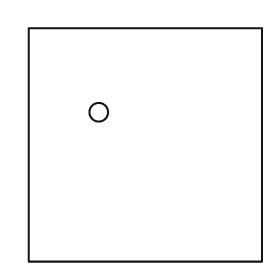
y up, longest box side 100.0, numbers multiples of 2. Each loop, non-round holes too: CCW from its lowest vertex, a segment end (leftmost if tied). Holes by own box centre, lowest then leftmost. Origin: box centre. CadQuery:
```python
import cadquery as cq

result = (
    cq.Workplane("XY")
    .moveTo(-50.0, -50.0)
    .lineTo(50.0, -50.0)
    .lineTo(50.0, 50.0)
    .lineTo(-50.0, 50.0)
    .close()
    .moveTo(-20.0, 14.0)
    .circle(4.0)
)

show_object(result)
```